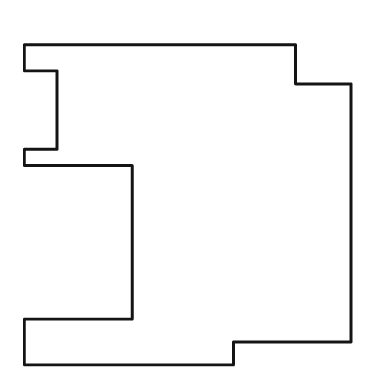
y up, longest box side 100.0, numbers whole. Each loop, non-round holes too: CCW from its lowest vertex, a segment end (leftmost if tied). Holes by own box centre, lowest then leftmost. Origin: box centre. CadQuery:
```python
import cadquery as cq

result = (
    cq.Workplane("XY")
    .moveTo(-50.0, -49.0)
    .lineTo(14.0, -49.0)
    .lineTo(14.0, -42.0)
    .lineTo(50.0, -42.0)
    .lineTo(50.0, 37.0)
    .lineTo(33.0, 37.0)
    .lineTo(33.0, 49.0)
    .lineTo(-50.0, 49.0)
    .lineTo(-50.0, 41.0)
    .lineTo(-40.0, 41.0)
    .lineTo(-40.0, 17.0)
    .lineTo(-50.0, 17.0)
    .lineTo(-50.0, 12.0)
    .lineTo(-17.0, 12.0)
    .lineTo(-17.0, -35.0)
    .lineTo(-50.0, -35.0)
    .close()
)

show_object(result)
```